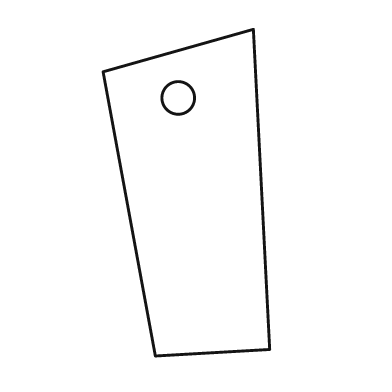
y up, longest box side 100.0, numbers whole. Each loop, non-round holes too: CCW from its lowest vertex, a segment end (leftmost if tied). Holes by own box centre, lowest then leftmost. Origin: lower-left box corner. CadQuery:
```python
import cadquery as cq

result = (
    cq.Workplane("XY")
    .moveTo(16.0, 0.0)
    .lineTo(51.0, 2.0)
    .lineTo(46.0, 100.0)
    .lineTo(0.0, 87.0)
    .close()
    .moveTo(23.0, 79.0)
    .circle(5.0)
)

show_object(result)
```